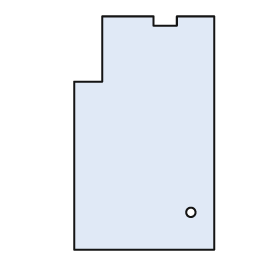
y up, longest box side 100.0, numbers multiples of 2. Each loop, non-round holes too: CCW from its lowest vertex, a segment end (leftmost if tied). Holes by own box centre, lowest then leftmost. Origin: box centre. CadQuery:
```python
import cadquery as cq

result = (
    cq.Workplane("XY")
    .moveTo(-30.0, -50.0)
    .lineTo(30.0, -50.0)
    .lineTo(30.0, 50.0)
    .lineTo(14.0, 50.0)
    .lineTo(14.0, 46.0)
    .lineTo(4.0, 46.0)
    .lineTo(4.0, 50.0)
    .lineTo(-18.0, 50.0)
    .lineTo(-18.0, 22.0)
    .lineTo(-30.0, 22.0)
    .close()
    .moveTo(20.0, -34.0)
    .circle(2.0)
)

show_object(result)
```